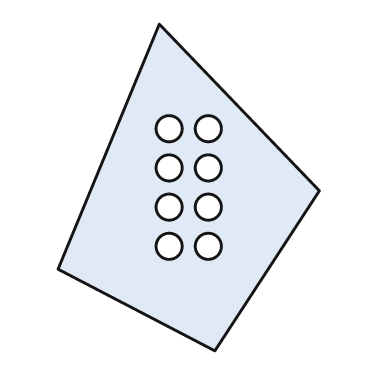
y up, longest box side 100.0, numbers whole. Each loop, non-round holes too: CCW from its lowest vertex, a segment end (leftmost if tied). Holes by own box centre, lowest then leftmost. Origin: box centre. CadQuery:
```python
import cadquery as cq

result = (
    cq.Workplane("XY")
    .moveTo(8.0, -50.0)
    .lineTo(40.0, -1.0)
    .lineTo(-9.0, 50.0)
    .lineTo(-40.0, -25.0)
    .close()
    .moveTo(-6.0, -18.0)
    .circle(4.0)
    .moveTo(6.0, -18.0)
    .circle(4.0)
    .moveTo(-6.0, -6.0)
    .circle(4.0)
    .moveTo(6.0, -6.0)
    .circle(4.0)
    .moveTo(-6.0, 6.0)
    .circle(4.0)
    .moveTo(6.0, 6.0)
    .circle(4.0)
    .moveTo(-6.0, 18.0)
    .circle(4.0)
    .moveTo(6.0, 18.0)
    .circle(4.0)
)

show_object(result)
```